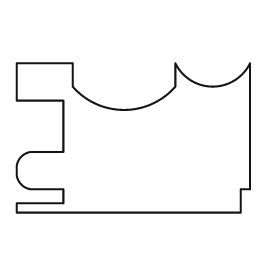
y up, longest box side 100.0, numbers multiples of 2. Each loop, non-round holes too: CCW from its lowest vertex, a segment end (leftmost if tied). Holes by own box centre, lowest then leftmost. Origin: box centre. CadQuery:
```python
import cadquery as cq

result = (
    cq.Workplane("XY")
    .moveTo(-50.0, -32.0)
    .lineTo(46.0, -32.0)
    .lineTo(46.0, -22.0)
    .lineTo(50.0, -22.0)
    .lineTo(50.0, 32.0)
    .threePointArc((34.0, 22.0), (18.0, 32.0))
    .lineTo(18.0, 22.0)
    .threePointArc((-4.0, 12.0), (-26.0, 22.0))
    .lineTo(-26.0, 32.0)
    .lineTo(-50.0, 32.0)
    .lineTo(-50.0, 16.0)
    .lineTo(-30.0, 16.0)
    .lineTo(-30.0, -6.0)
    .lineTo(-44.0, -6.0)
    .threePointArc((-48.0, -8.0), (-50.0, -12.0))
    .lineTo(-50.0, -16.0)
    .threePointArc((-48.0, -20.0), (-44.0, -22.0))
    .lineTo(-30.0, -22.0)
    .lineTo(-30.0, -28.0)
    .lineTo(-50.0, -28.0)
    .close()
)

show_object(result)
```